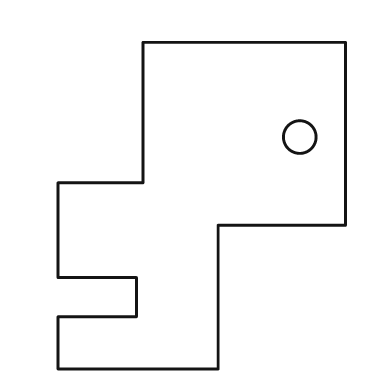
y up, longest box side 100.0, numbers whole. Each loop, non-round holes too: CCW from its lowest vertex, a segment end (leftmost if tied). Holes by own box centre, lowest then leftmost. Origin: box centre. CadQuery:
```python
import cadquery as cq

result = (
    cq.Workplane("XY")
    .moveTo(-44.0, -50.0)
    .lineTo(5.0, -50.0)
    .lineTo(5.0, -6.0)
    .lineTo(44.0, -6.0)
    .lineTo(44.0, 50.0)
    .lineTo(-18.0, 50.0)
    .lineTo(-18.0, 7.0)
    .lineTo(-44.0, 7.0)
    .lineTo(-44.0, -22.0)
    .lineTo(-20.0, -22.0)
    .lineTo(-20.0, -34.0)
    .lineTo(-44.0, -34.0)
    .close()
    .moveTo(30.0, 21.0)
    .circle(5.0)
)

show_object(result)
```